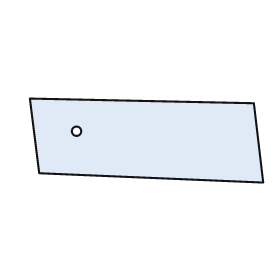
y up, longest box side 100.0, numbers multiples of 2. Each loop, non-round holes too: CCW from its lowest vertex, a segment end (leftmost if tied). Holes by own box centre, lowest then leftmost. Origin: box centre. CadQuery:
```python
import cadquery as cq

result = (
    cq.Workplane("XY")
    .moveTo(50.0, -18.0)
    .lineTo(46.0, 16.0)
    .lineTo(-50.0, 18.0)
    .lineTo(-46.0, -14.0)
    .close()
    .moveTo(-30.0, 4.0)
    .circle(2.0)
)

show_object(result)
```